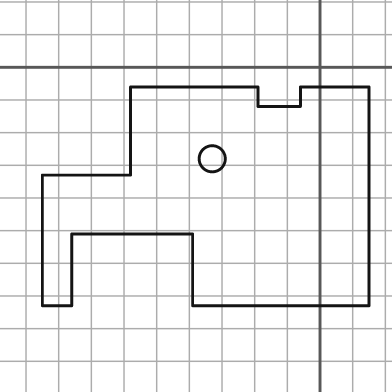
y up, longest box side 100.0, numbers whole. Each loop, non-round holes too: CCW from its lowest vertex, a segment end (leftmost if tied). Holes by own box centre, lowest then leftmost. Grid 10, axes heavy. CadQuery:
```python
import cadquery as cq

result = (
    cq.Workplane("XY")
    .moveTo(-85.0, -73.0)
    .lineTo(-76.0, -73.0)
    .lineTo(-76.0, -51.0)
    .lineTo(-39.0, -51.0)
    .lineTo(-39.0, -73.0)
    .lineTo(15.0, -73.0)
    .lineTo(15.0, -6.0)
    .lineTo(-6.0, -6.0)
    .lineTo(-6.0, -12.0)
    .lineTo(-19.0, -12.0)
    .lineTo(-19.0, -6.0)
    .lineTo(-58.0, -6.0)
    .lineTo(-58.0, -33.0)
    .lineTo(-85.0, -33.0)
    .close()
    .moveTo(-33.0, -28.0)
    .circle(4.0)
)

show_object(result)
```